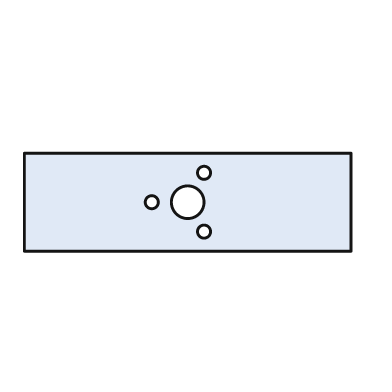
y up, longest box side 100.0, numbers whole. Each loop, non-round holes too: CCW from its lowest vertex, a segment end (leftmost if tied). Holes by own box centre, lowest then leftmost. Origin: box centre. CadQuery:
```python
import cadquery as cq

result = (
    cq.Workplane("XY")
    .moveTo(-50.0, -15.0)
    .lineTo(50.0, -15.0)
    .lineTo(50.0, 15.0)
    .lineTo(-50.0, 15.0)
    .close()
    .moveTo(5.0, -9.0)
    .circle(2.0)
    .moveTo(-11.0, 0.0)
    .circle(2.0)
    .moveTo(0.0, 0.0)
    .circle(5.0)
    .moveTo(5.0, 9.0)
    .circle(2.0)
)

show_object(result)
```